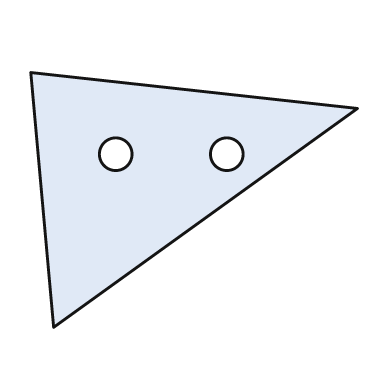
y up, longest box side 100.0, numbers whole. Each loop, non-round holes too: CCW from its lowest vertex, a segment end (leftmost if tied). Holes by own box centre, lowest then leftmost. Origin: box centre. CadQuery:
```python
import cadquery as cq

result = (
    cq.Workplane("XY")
    .moveTo(-43.0, -39.0)
    .lineTo(50.0, 28.0)
    .lineTo(-50.0, 39.0)
    .close()
    .moveTo(-24.0, 14.0)
    .circle(5.0)
    .moveTo(10.0, 14.0)
    .circle(5.0)
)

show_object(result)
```